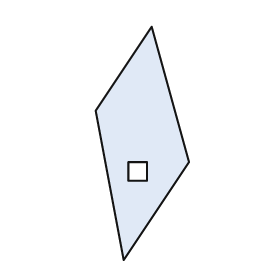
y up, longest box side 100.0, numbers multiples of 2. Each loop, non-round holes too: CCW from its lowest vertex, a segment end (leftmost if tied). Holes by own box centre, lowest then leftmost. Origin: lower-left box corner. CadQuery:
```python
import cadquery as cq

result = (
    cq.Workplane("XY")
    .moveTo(12.0, 0.0)
    .lineTo(40.0, 42.0)
    .lineTo(24.0, 100.0)
    .lineTo(0.0, 64.0)
    .close()
    .moveTo(14.0, 34.0)
    .lineTo(22.0, 34.0)
    .lineTo(22.0, 42.0)
    .lineTo(14.0, 42.0)
    .close()
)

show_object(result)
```